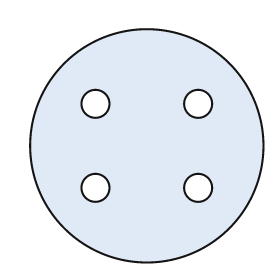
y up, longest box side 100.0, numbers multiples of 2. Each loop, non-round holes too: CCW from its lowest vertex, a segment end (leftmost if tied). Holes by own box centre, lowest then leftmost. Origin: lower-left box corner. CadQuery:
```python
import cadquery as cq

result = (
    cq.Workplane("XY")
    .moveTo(50.0, 50.0)
    .circle(50.0)
    .moveTo(28.0, 32.0)
    .circle(6.0)
    .moveTo(72.0, 32.0)
    .circle(6.0)
    .moveTo(28.0, 68.0)
    .circle(6.0)
    .moveTo(72.0, 68.0)
    .circle(6.0)
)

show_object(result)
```